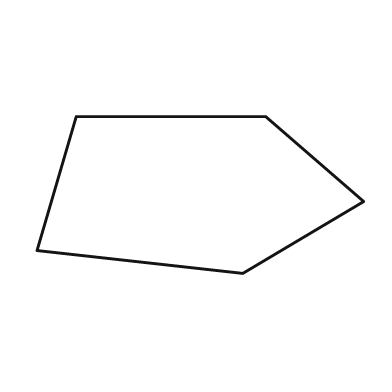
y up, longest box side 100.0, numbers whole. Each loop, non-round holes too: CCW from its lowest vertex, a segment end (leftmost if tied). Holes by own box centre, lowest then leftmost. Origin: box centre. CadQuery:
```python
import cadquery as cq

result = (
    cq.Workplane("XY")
    .moveTo(13.0, -24.0)
    .lineTo(50.0, -2.0)
    .lineTo(20.0, 24.0)
    .lineTo(-38.0, 24.0)
    .lineTo(-50.0, -17.0)
    .close()
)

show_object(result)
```